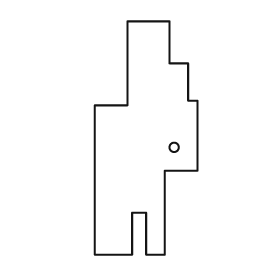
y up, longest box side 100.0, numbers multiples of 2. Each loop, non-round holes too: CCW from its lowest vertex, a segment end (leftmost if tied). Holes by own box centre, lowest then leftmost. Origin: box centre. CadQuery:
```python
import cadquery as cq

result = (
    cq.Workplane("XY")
    .moveTo(-22.0, -50.0)
    .lineTo(-6.0, -50.0)
    .lineTo(-6.0, -32.0)
    .lineTo(0.0, -32.0)
    .lineTo(0.0, -50.0)
    .lineTo(8.0, -50.0)
    .lineTo(8.0, -14.0)
    .lineTo(22.0, -14.0)
    .lineTo(22.0, 16.0)
    .lineTo(18.0, 16.0)
    .lineTo(18.0, 32.0)
    .lineTo(10.0, 32.0)
    .lineTo(10.0, 50.0)
    .lineTo(-8.0, 50.0)
    .lineTo(-8.0, 14.0)
    .lineTo(-22.0, 14.0)
    .close()
    .moveTo(12.0, -4.0)
    .circle(2.0)
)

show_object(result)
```